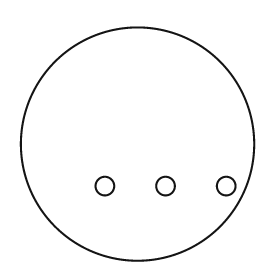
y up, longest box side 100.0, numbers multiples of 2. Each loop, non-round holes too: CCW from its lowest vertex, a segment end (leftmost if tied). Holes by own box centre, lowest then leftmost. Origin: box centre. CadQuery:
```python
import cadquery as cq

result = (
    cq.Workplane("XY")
    .moveTo(0.0, 0.0)
    .circle(50.0)
    .moveTo(-14.0, -18.0)
    .circle(4.0)
    .moveTo(12.0, -18.0)
    .circle(4.0)
    .moveTo(38.0, -18.0)
    .circle(4.0)
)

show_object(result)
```